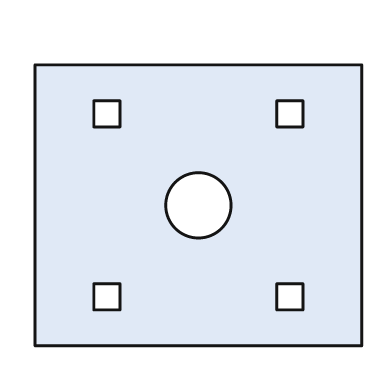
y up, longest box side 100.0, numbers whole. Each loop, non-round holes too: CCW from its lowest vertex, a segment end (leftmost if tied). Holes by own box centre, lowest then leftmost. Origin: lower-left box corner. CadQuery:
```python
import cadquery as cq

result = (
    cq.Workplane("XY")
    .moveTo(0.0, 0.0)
    .lineTo(100.0, 0.0)
    .lineTo(100.0, 86.0)
    .lineTo(0.0, 86.0)
    .close()
    .moveTo(18.0, 11.0)
    .lineTo(26.0, 11.0)
    .lineTo(26.0, 19.0)
    .lineTo(18.0, 19.0)
    .close()
    .moveTo(74.0, 11.0)
    .lineTo(82.0, 11.0)
    .lineTo(82.0, 19.0)
    .lineTo(74.0, 19.0)
    .close()
    .moveTo(50.0, 43.0)
    .circle(10.0)
    .moveTo(18.0, 67.0)
    .lineTo(26.0, 67.0)
    .lineTo(26.0, 75.0)
    .lineTo(18.0, 75.0)
    .close()
    .moveTo(74.0, 67.0)
    .lineTo(82.0, 67.0)
    .lineTo(82.0, 75.0)
    .lineTo(74.0, 75.0)
    .close()
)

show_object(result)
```